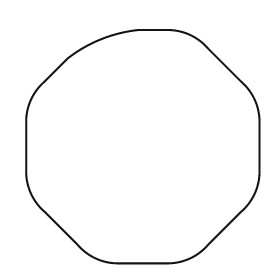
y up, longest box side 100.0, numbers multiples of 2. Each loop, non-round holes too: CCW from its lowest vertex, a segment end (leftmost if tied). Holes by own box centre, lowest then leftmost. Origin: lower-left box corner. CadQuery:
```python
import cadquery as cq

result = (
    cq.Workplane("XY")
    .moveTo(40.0, 0.0)
    .lineTo(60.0, 0.0)
    .threePointArc((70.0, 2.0), (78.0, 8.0))
    .lineTo(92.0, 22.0)
    .threePointArc((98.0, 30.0), (100.0, 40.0))
    .lineTo(100.0, 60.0)
    .threePointArc((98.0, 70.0), (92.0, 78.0))
    .lineTo(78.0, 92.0)
    .threePointArc((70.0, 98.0), (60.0, 100.0))
    .lineTo(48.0, 100.0)
    .threePointArc((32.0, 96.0), (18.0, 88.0))
    .lineTo(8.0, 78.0)
    .threePointArc((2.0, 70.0), (0.0, 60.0))
    .lineTo(0.0, 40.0)
    .threePointArc((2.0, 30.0), (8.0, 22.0))
    .lineTo(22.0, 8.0)
    .threePointArc((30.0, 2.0), (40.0, 0.0))
    .close()
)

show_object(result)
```